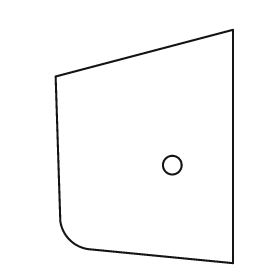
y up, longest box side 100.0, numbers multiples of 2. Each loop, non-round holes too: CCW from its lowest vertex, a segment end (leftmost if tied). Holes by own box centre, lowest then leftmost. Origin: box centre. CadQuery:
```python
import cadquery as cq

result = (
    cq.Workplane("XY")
    .moveTo(38.0, -50.0)
    .lineTo(38.0, 50.0)
    .lineTo(-38.0, 30.0)
    .lineTo(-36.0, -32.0)
    .threePointArc((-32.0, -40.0), (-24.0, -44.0))
    .close()
    .moveTo(12.0, -8.0)
    .circle(4.0)
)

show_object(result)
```